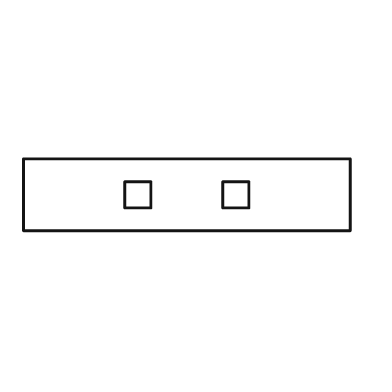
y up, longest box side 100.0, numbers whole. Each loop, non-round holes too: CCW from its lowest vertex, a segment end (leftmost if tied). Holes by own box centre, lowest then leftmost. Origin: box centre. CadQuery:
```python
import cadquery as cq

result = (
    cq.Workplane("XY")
    .moveTo(-50.0, -11.0)
    .lineTo(50.0, -11.0)
    .lineTo(50.0, 11.0)
    .lineTo(-50.0, 11.0)
    .close()
    .moveTo(-19.0, -4.0)
    .lineTo(-11.0, -4.0)
    .lineTo(-11.0, 4.0)
    .lineTo(-19.0, 4.0)
    .close()
    .moveTo(11.0, -4.0)
    .lineTo(19.0, -4.0)
    .lineTo(19.0, 4.0)
    .lineTo(11.0, 4.0)
    .close()
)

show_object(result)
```